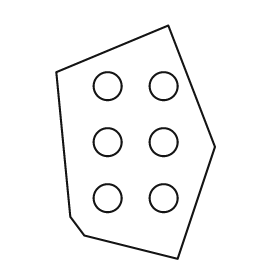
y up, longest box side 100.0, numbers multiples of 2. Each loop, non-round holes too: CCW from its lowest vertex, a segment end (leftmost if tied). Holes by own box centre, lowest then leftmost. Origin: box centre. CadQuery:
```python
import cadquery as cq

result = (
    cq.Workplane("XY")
    .moveTo(18.0, -50.0)
    .lineTo(34.0, -2.0)
    .lineTo(14.0, 50.0)
    .lineTo(-34.0, 30.0)
    .lineTo(-28.0, -32.0)
    .lineTo(-22.0, -40.0)
    .close()
    .moveTo(-12.0, -24.0)
    .circle(6.0)
    .moveTo(12.0, -24.0)
    .circle(6.0)
    .moveTo(-12.0, 0.0)
    .circle(6.0)
    .moveTo(12.0, 0.0)
    .circle(6.0)
    .moveTo(-12.0, 24.0)
    .circle(6.0)
    .moveTo(12.0, 24.0)
    .circle(6.0)
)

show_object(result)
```